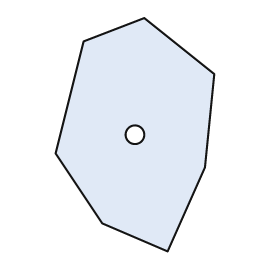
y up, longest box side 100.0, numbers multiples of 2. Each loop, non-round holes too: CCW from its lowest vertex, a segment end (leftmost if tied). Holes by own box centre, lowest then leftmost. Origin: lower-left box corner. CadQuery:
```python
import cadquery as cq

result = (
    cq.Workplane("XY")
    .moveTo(48.0, 0.0)
    .lineTo(64.0, 36.0)
    .lineTo(68.0, 76.0)
    .lineTo(38.0, 100.0)
    .lineTo(12.0, 90.0)
    .lineTo(0.0, 42.0)
    .lineTo(20.0, 12.0)
    .close()
    .moveTo(34.0, 50.0)
    .circle(4.0)
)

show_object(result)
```